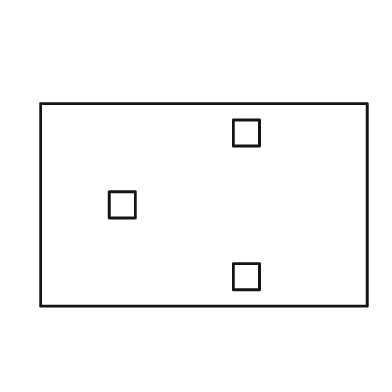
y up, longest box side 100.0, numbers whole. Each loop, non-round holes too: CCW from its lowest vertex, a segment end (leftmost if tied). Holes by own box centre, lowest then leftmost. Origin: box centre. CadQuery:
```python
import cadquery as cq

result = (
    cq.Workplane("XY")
    .moveTo(-50.0, -31.0)
    .lineTo(50.0, -31.0)
    .lineTo(50.0, 31.0)
    .lineTo(-50.0, 31.0)
    .close()
    .moveTo(9.0, -26.0)
    .lineTo(17.0, -26.0)
    .lineTo(17.0, -18.0)
    .lineTo(9.0, -18.0)
    .close()
    .moveTo(-29.0, -4.0)
    .lineTo(-21.0, -4.0)
    .lineTo(-21.0, 4.0)
    .lineTo(-29.0, 4.0)
    .close()
    .moveTo(9.0, 18.0)
    .lineTo(17.0, 18.0)
    .lineTo(17.0, 26.0)
    .lineTo(9.0, 26.0)
    .close()
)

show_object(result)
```